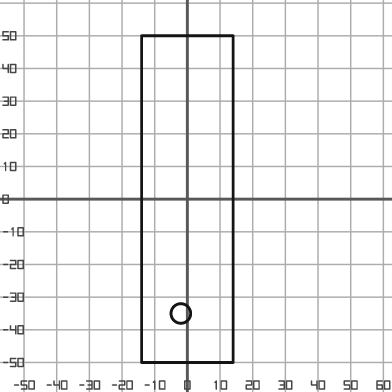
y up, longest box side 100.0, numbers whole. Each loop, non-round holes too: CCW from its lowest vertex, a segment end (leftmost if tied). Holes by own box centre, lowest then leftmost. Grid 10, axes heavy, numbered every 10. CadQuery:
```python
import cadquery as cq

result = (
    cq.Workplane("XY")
    .moveTo(-14.0, -50.0)
    .lineTo(14.0, -50.0)
    .lineTo(14.0, 50.0)
    .lineTo(-14.0, 50.0)
    .close()
    .moveTo(-2.0, -35.0)
    .circle(3.0)
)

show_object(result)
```